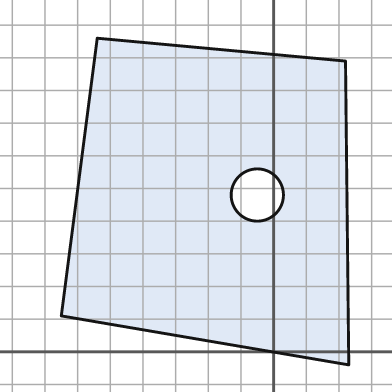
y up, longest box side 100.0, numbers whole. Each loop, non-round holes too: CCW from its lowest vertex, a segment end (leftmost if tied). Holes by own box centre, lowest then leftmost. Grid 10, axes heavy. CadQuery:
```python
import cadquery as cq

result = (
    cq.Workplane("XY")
    .moveTo(23.0, -4.0)
    .lineTo(22.0, 89.0)
    .lineTo(-54.0, 96.0)
    .lineTo(-65.0, 11.0)
    .close()
    .moveTo(-5.0, 48.0)
    .circle(8.0)
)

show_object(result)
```